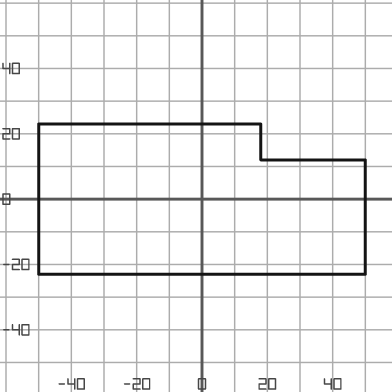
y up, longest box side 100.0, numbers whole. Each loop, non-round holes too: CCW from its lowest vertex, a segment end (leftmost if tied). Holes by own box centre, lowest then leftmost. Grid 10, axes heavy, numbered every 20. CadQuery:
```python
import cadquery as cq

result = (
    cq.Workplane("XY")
    .moveTo(-50.0, -23.0)
    .lineTo(50.0, -23.0)
    .lineTo(50.0, 12.0)
    .lineTo(18.0, 12.0)
    .lineTo(18.0, 23.0)
    .lineTo(-50.0, 23.0)
    .close()
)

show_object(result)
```